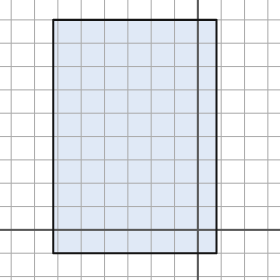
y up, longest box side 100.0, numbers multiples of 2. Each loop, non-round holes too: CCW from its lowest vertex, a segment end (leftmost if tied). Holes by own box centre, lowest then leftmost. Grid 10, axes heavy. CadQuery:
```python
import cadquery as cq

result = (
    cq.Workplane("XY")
    .moveTo(-62.0, -10.0)
    .lineTo(8.0, -10.0)
    .lineTo(8.0, 90.0)
    .lineTo(-62.0, 90.0)
    .close()
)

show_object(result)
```